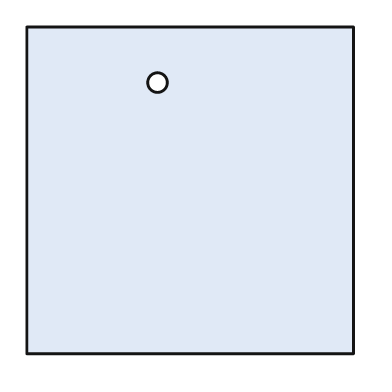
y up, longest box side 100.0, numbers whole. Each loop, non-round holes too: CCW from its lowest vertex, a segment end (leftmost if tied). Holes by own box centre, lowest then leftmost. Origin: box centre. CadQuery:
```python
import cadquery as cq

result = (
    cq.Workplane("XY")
    .moveTo(-50.0, -50.0)
    .lineTo(50.0, -50.0)
    .lineTo(50.0, 50.0)
    .lineTo(-50.0, 50.0)
    .close()
    .moveTo(-10.0, 33.0)
    .circle(3.0)
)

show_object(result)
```